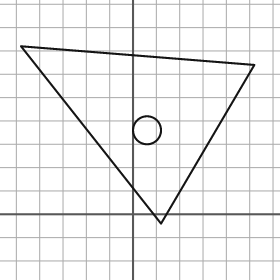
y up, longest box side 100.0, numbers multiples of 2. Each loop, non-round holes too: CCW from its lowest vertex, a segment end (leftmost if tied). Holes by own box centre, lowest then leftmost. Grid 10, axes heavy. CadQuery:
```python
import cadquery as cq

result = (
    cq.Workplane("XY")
    .moveTo(12.0, -4.0)
    .lineTo(52.0, 64.0)
    .lineTo(-48.0, 72.0)
    .close()
    .moveTo(6.0, 36.0)
    .circle(6.0)
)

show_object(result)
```